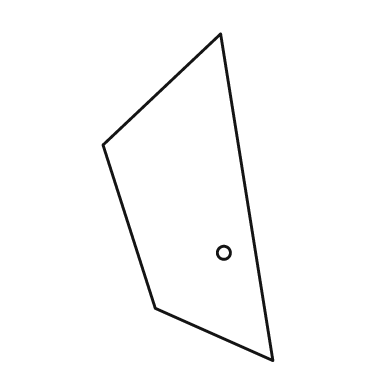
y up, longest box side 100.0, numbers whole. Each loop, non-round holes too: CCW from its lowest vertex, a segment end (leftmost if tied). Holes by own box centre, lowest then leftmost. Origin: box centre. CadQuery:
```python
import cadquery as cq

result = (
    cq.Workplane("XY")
    .moveTo(26.0, -50.0)
    .lineTo(10.0, 50.0)
    .lineTo(-26.0, 16.0)
    .lineTo(-10.0, -34.0)
    .close()
    .moveTo(11.0, -17.0)
    .circle(2.0)
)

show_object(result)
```